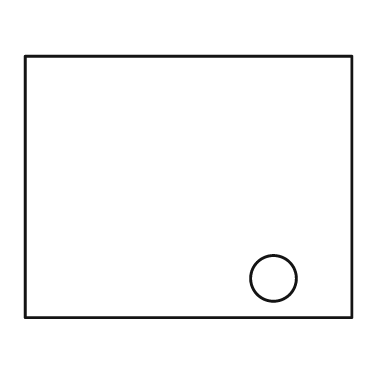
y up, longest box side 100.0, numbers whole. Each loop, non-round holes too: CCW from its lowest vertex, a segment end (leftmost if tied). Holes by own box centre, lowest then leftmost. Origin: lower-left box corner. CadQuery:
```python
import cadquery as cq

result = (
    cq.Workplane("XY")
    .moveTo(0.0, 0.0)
    .lineTo(100.0, 0.0)
    .lineTo(100.0, 80.0)
    .lineTo(0.0, 80.0)
    .close()
    .moveTo(76.0, 12.0)
    .circle(7.0)
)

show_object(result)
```